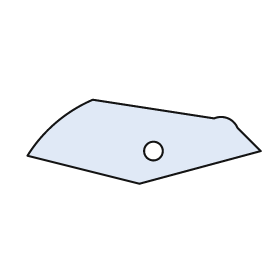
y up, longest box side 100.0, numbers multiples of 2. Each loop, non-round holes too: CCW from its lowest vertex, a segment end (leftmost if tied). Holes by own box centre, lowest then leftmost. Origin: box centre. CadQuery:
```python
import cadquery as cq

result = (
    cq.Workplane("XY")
    .moveTo(-2.0, -18.0)
    .lineTo(50.0, -4.0)
    .lineTo(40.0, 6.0)
    .threePointArc((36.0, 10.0), (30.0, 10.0))
    .lineTo(-22.0, 18.0)
    .threePointArc((-38.0, 8.0), (-50.0, -6.0))
    .close()
    .moveTo(4.0, -4.0)
    .circle(4.0)
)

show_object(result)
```